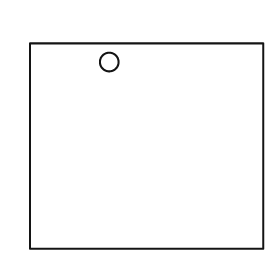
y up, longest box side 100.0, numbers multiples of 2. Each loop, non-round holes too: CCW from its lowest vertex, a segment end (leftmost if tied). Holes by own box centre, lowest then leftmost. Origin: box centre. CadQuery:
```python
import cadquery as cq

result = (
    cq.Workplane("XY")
    .moveTo(-50.0, -44.0)
    .lineTo(50.0, -44.0)
    .lineTo(50.0, 44.0)
    .lineTo(-50.0, 44.0)
    .close()
    .moveTo(-16.0, 36.0)
    .circle(4.0)
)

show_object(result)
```